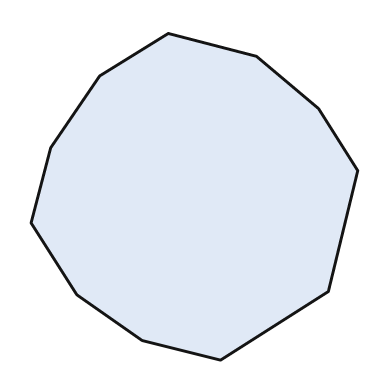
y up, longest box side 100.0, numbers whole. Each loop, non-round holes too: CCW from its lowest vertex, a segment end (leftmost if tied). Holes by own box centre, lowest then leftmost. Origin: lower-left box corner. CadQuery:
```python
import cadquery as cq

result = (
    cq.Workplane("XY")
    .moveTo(58.0, 0.0)
    .lineTo(91.0, 21.0)
    .lineTo(100.0, 58.0)
    .lineTo(88.0, 77.0)
    .lineTo(69.0, 93.0)
    .lineTo(42.0, 100.0)
    .lineTo(21.0, 87.0)
    .lineTo(6.0, 65.0)
    .lineTo(0.0, 42.0)
    .lineTo(14.0, 20.0)
    .lineTo(34.0, 6.0)
    .close()
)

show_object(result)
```